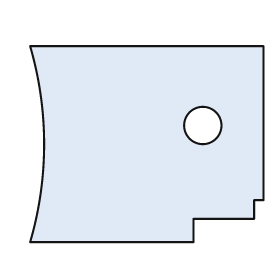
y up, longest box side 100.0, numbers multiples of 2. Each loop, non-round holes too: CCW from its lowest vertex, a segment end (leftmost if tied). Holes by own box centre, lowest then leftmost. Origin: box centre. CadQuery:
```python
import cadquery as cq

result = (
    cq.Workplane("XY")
    .moveTo(-50.0, -42.0)
    .lineTo(20.0, -42.0)
    .lineTo(20.0, -32.0)
    .lineTo(46.0, -32.0)
    .lineTo(46.0, -24.0)
    .lineTo(50.0, -24.0)
    .lineTo(50.0, 42.0)
    .lineTo(-50.0, 42.0)
    .threePointArc((-44.0, 0.0), (-50.0, -42.0))
    .close()
    .moveTo(24.0, 8.0)
    .circle(8.0)
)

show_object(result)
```